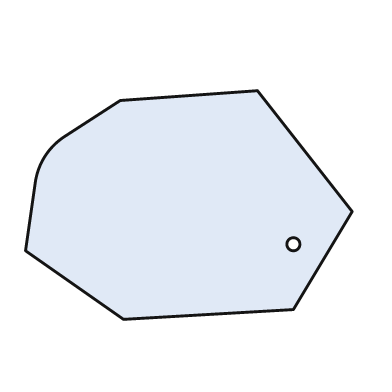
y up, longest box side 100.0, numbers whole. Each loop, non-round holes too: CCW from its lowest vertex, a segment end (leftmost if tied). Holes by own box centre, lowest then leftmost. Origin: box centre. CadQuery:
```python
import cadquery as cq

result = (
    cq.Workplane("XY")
    .moveTo(-20.0, -35.0)
    .lineTo(32.0, -32.0)
    .lineTo(50.0, -2.0)
    .lineTo(21.0, 35.0)
    .lineTo(-21.0, 32.0)
    .lineTo(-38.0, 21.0)
    .threePointArc((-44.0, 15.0), (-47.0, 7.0))
    .lineTo(-50.0, -14.0)
    .close()
    .moveTo(32.0, -12.0)
    .circle(2.0)
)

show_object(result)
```